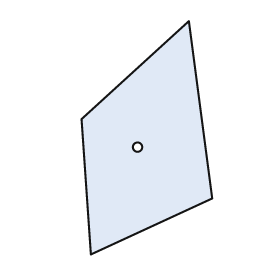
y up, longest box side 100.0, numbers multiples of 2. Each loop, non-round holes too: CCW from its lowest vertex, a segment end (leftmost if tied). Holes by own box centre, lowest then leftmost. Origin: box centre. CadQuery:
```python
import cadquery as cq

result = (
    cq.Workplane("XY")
    .moveTo(-24.0, -50.0)
    .lineTo(28.0, -26.0)
    .lineTo(18.0, 50.0)
    .lineTo(-28.0, 8.0)
    .close()
    .moveTo(-4.0, -4.0)
    .circle(2.0)
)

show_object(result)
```